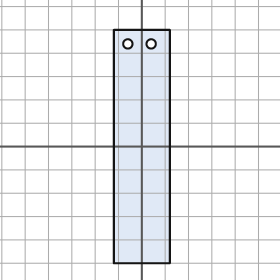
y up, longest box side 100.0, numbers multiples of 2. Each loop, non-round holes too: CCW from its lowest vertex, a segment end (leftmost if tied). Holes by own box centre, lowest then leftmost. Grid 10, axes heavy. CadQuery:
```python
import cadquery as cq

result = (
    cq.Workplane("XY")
    .moveTo(-12.0, -50.0)
    .lineTo(12.0, -50.0)
    .lineTo(12.0, 50.0)
    .lineTo(-12.0, 50.0)
    .close()
    .moveTo(-6.0, 44.0)
    .circle(2.0)
    .moveTo(4.0, 44.0)
    .circle(2.0)
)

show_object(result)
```